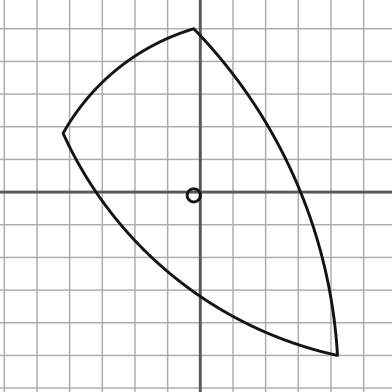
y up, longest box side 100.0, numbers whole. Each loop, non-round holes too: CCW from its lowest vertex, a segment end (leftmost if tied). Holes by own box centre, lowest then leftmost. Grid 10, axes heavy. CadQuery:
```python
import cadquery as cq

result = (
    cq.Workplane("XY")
    .moveTo(42.0, -50.0)
    .threePointArc((29.0, 4.0), (-2.0, 50.0))
    .threePointArc((-25.0, 38.0), (-42.0, 18.0))
    .threePointArc((-8.0, -26.0), (42.0, -50.0))
    .close()
    .moveTo(-2.0, -1.0)
    .circle(2.0)
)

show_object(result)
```